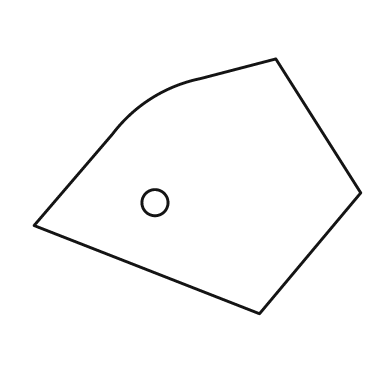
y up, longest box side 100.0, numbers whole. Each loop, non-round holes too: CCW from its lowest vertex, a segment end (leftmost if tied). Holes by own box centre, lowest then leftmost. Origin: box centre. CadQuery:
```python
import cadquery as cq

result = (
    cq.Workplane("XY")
    .moveTo(19.0, -39.0)
    .lineTo(50.0, -2.0)
    .lineTo(24.0, 39.0)
    .lineTo(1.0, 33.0)
    .threePointArc((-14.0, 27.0), (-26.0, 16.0))
    .lineTo(-50.0, -12.0)
    .close()
    .moveTo(-13.0, -5.0)
    .circle(4.0)
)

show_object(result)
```